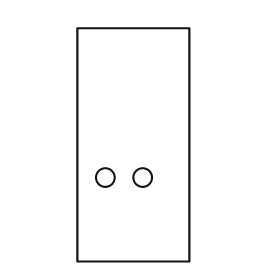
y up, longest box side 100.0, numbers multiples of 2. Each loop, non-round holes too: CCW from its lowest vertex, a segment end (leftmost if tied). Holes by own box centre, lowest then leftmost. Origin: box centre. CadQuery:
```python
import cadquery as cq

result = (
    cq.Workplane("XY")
    .moveTo(-24.0, -50.0)
    .lineTo(24.0, -50.0)
    .lineTo(24.0, 50.0)
    .lineTo(-24.0, 50.0)
    .close()
    .moveTo(-12.0, -14.0)
    .circle(4.0)
    .moveTo(4.0, -14.0)
    .circle(4.0)
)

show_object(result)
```